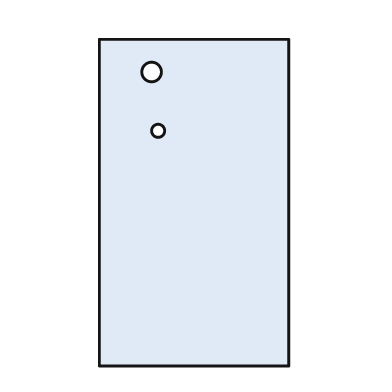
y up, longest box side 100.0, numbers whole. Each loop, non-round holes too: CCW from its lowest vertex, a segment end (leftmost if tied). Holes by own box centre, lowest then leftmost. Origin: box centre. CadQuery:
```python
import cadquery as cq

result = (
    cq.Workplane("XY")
    .moveTo(-29.0, -50.0)
    .lineTo(29.0, -50.0)
    .lineTo(29.0, 50.0)
    .lineTo(-29.0, 50.0)
    .close()
    .moveTo(-11.0, 22.0)
    .circle(2.0)
    .moveTo(-13.0, 40.0)
    .circle(3.0)
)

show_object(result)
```